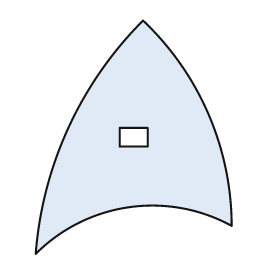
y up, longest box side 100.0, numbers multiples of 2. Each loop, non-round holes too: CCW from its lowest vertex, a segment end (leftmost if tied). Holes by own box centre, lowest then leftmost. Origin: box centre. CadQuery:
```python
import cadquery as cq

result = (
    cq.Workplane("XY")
    .moveTo(-42.0, -50.0)
    .threePointArc((-2.0, -30.0), (42.0, -38.0))
    .threePointArc((32.0, 10.0), (4.0, 50.0))
    .threePointArc((-28.0, 4.0), (-42.0, -50.0))
    .close()
    .moveTo(-6.0, -4.0)
    .lineTo(6.0, -4.0)
    .lineTo(6.0, 4.0)
    .lineTo(-6.0, 4.0)
    .close()
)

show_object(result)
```